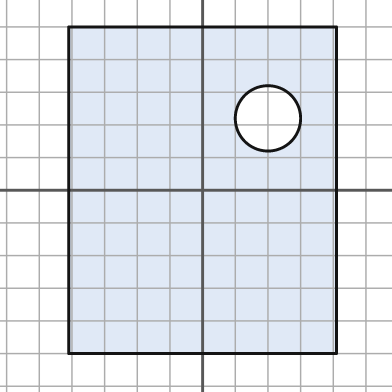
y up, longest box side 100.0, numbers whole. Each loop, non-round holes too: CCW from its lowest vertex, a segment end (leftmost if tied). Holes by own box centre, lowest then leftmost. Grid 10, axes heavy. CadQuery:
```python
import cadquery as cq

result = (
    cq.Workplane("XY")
    .moveTo(-41.0, -50.0)
    .lineTo(41.0, -50.0)
    .lineTo(41.0, 50.0)
    .lineTo(-41.0, 50.0)
    .close()
    .moveTo(20.0, 22.0)
    .circle(10.0)
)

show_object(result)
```